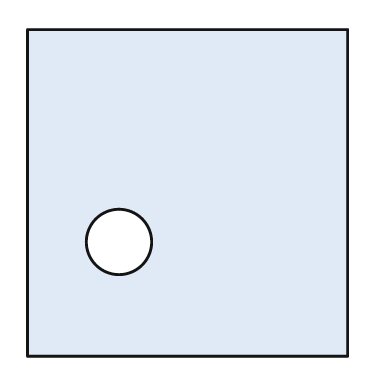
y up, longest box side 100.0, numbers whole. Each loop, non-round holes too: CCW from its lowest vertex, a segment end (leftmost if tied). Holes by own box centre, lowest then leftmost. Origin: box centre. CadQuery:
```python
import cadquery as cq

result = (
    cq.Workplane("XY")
    .moveTo(-49.0, -50.0)
    .lineTo(49.0, -50.0)
    .lineTo(49.0, 50.0)
    .lineTo(-49.0, 50.0)
    .close()
    .moveTo(-21.0, -15.0)
    .circle(10.0)
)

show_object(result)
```